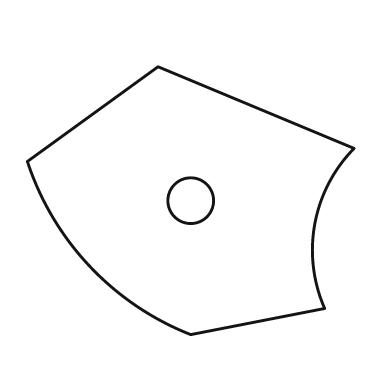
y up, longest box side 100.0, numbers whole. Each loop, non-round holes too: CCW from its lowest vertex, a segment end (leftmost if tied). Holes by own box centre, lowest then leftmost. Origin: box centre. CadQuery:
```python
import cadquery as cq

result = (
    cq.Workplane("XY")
    .moveTo(0.0, -41.0)
    .lineTo(41.0, -33.0)
    .threePointArc((38.0, -7.0), (50.0, 16.0))
    .lineTo(-10.0, 41.0)
    .lineTo(-50.0, 12.0)
    .threePointArc((-31.0, -20.0), (0.0, -41.0))
    .close()
    .moveTo(0.0, 0.0)
    .circle(7.0)
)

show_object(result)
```